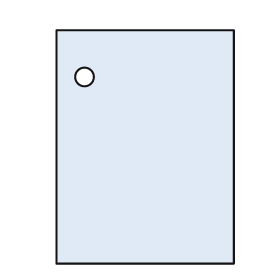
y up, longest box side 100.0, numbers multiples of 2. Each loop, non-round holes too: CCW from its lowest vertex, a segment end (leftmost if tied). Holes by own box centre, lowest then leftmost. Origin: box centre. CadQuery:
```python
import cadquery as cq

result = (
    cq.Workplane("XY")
    .moveTo(-38.0, -50.0)
    .lineTo(38.0, -50.0)
    .lineTo(38.0, 50.0)
    .lineTo(-38.0, 50.0)
    .close()
    .moveTo(-26.0, 30.0)
    .circle(4.0)
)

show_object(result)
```